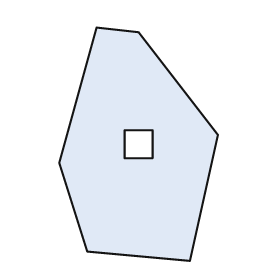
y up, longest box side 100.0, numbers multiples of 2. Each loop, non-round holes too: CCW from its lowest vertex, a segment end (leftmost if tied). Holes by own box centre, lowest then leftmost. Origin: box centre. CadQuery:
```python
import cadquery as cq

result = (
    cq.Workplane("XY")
    .moveTo(22.0, -50.0)
    .lineTo(34.0, 4.0)
    .lineTo(0.0, 48.0)
    .lineTo(-18.0, 50.0)
    .lineTo(-34.0, -8.0)
    .lineTo(-22.0, -46.0)
    .close()
    .moveTo(-6.0, -6.0)
    .lineTo(6.0, -6.0)
    .lineTo(6.0, 6.0)
    .lineTo(-6.0, 6.0)
    .close()
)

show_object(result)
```